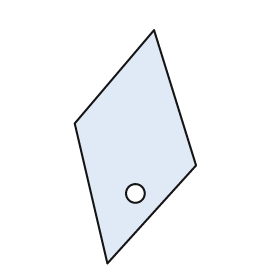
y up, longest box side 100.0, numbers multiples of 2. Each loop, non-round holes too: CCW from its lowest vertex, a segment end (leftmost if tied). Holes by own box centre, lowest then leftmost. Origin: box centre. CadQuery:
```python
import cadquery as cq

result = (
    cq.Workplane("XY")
    .moveTo(-12.0, -50.0)
    .lineTo(26.0, -8.0)
    .lineTo(8.0, 50.0)
    .lineTo(-26.0, 10.0)
    .close()
    .moveTo(0.0, -20.0)
    .circle(4.0)
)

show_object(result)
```